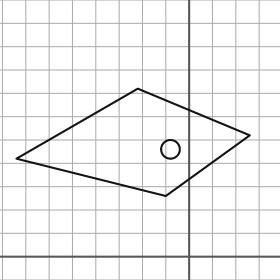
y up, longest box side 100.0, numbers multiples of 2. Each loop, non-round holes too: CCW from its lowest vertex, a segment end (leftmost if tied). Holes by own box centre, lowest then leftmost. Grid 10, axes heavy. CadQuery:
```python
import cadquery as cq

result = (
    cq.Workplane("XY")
    .moveTo(-10.0, 26.0)
    .lineTo(26.0, 52.0)
    .lineTo(-22.0, 72.0)
    .lineTo(-74.0, 42.0)
    .close()
    .moveTo(-8.0, 46.0)
    .circle(4.0)
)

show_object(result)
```